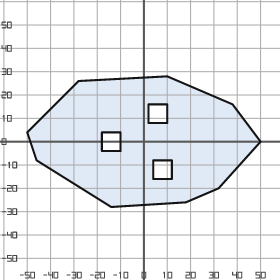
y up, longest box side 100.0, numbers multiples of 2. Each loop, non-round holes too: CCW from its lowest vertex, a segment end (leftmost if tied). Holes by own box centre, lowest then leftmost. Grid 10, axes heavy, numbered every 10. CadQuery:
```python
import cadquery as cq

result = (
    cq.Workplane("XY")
    .moveTo(-14.0, -28.0)
    .lineTo(18.0, -26.0)
    .lineTo(32.0, -20.0)
    .lineTo(50.0, 0.0)
    .lineTo(38.0, 16.0)
    .lineTo(10.0, 28.0)
    .lineTo(-28.0, 26.0)
    .lineTo(-50.0, 4.0)
    .lineTo(-46.0, -8.0)
    .close()
    .moveTo(4.0, -16.0)
    .lineTo(12.0, -16.0)
    .lineTo(12.0, -8.0)
    .lineTo(4.0, -8.0)
    .close()
    .moveTo(-18.0, -4.0)
    .lineTo(-10.0, -4.0)
    .lineTo(-10.0, 4.0)
    .lineTo(-18.0, 4.0)
    .close()
    .moveTo(2.0, 8.0)
    .lineTo(10.0, 8.0)
    .lineTo(10.0, 16.0)
    .lineTo(2.0, 16.0)
    .close()
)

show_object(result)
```